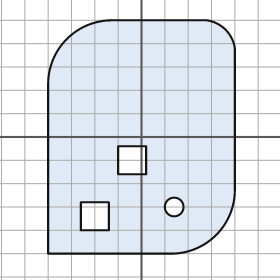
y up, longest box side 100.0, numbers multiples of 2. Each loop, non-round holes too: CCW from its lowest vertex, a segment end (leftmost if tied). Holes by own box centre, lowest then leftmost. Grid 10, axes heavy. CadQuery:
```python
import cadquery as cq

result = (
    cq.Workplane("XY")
    .moveTo(-40.0, -50.0)
    .lineTo(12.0, -50.0)
    .threePointArc((32.0, -42.0), (40.0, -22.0))
    .lineTo(40.0, 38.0)
    .threePointArc((36.0, 46.0), (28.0, 50.0))
    .lineTo(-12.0, 50.0)
    .threePointArc((-32.0, 42.0), (-40.0, 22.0))
    .close()
    .moveTo(-26.0, -40.0)
    .lineTo(-14.0, -40.0)
    .lineTo(-14.0, -28.0)
    .lineTo(-26.0, -28.0)
    .close()
    .moveTo(14.0, -30.0)
    .circle(4.0)
    .moveTo(-10.0, -16.0)
    .lineTo(2.0, -16.0)
    .lineTo(2.0, -4.0)
    .lineTo(-10.0, -4.0)
    .close()
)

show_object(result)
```